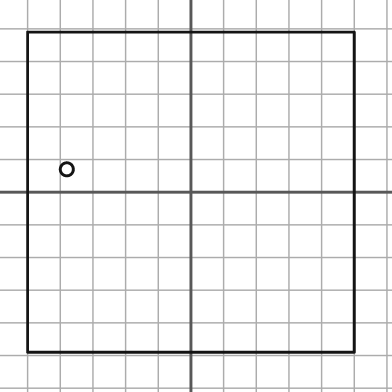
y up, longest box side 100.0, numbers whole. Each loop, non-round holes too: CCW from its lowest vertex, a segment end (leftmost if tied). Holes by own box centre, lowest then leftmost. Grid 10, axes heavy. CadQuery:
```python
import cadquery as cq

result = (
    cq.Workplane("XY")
    .moveTo(-50.0, -49.0)
    .lineTo(50.0, -49.0)
    .lineTo(50.0, 49.0)
    .lineTo(-50.0, 49.0)
    .close()
    .moveTo(-38.0, 7.0)
    .circle(2.0)
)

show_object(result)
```